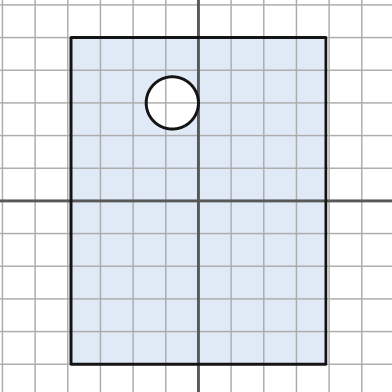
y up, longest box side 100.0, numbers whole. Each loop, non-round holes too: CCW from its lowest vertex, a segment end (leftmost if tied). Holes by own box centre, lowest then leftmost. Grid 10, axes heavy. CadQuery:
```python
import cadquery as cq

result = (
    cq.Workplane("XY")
    .moveTo(-39.0, -50.0)
    .lineTo(39.0, -50.0)
    .lineTo(39.0, 50.0)
    .lineTo(-39.0, 50.0)
    .close()
    .moveTo(-8.0, 30.0)
    .circle(8.0)
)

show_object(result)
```